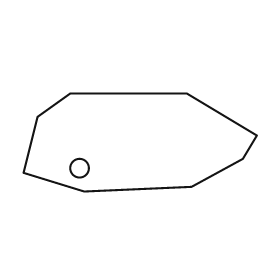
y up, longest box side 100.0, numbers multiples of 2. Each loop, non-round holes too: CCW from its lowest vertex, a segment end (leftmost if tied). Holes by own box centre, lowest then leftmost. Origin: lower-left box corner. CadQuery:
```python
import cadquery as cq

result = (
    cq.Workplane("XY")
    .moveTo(26.0, 0.0)
    .lineTo(72.0, 2.0)
    .lineTo(94.0, 14.0)
    .lineTo(100.0, 24.0)
    .lineTo(70.0, 42.0)
    .lineTo(20.0, 42.0)
    .lineTo(6.0, 32.0)
    .lineTo(0.0, 8.0)
    .close()
    .moveTo(24.0, 10.0)
    .circle(4.0)
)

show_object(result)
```